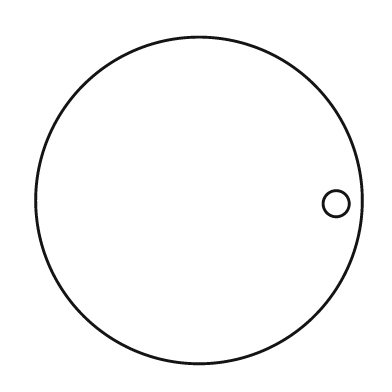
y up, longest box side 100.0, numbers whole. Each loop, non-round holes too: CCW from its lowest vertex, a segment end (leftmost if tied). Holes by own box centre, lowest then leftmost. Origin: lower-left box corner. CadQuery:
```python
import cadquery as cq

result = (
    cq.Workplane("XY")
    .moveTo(50.0, 50.0)
    .circle(50.0)
    .moveTo(92.0, 49.0)
    .circle(4.0)
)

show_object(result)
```